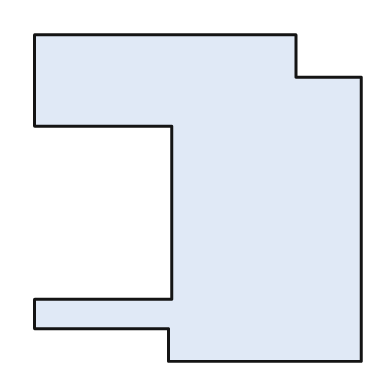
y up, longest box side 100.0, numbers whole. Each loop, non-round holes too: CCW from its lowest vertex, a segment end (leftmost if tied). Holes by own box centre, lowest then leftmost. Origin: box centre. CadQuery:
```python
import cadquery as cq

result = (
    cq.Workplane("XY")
    .moveTo(-9.0, -50.0)
    .lineTo(50.0, -50.0)
    .lineTo(50.0, 37.0)
    .lineTo(30.0, 37.0)
    .lineTo(30.0, 50.0)
    .lineTo(-50.0, 50.0)
    .lineTo(-50.0, 22.0)
    .lineTo(-8.0, 22.0)
    .lineTo(-8.0, -31.0)
    .lineTo(-50.0, -31.0)
    .lineTo(-50.0, -40.0)
    .lineTo(-9.0, -40.0)
    .close()
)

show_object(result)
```